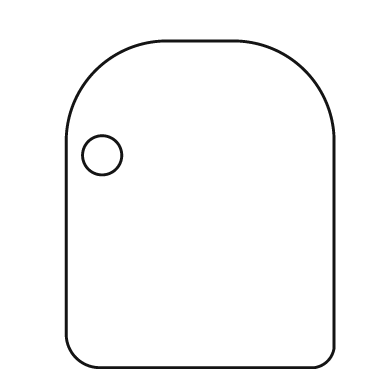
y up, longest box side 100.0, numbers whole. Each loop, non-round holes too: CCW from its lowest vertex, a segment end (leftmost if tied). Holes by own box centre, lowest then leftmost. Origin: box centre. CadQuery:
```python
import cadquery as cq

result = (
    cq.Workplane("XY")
    .moveTo(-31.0, -50.0)
    .lineTo(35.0, -50.0)
    .threePointArc((39.0, -48.0), (41.0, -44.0))
    .lineTo(41.0, 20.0)
    .threePointArc((32.0, 41.0), (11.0, 50.0))
    .lineTo(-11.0, 50.0)
    .threePointArc((-32.0, 41.0), (-41.0, 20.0))
    .lineTo(-41.0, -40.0)
    .threePointArc((-38.0, -47.0), (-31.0, -50.0))
    .close()
    .moveTo(-30.0, 15.0)
    .circle(6.0)
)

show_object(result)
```